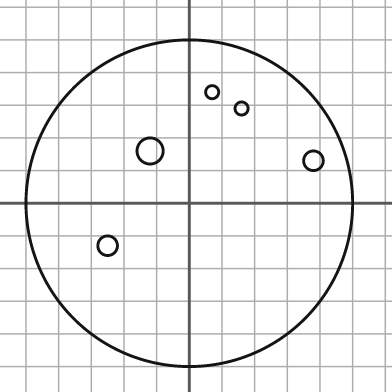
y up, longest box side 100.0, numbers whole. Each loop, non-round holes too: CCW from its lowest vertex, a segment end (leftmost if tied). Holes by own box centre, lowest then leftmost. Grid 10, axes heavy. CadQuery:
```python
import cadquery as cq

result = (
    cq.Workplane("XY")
    .moveTo(0.0, 0.0)
    .circle(50.0)
    .moveTo(-25.0, -13.0)
    .circle(3.0)
    .moveTo(38.0, 13.0)
    .circle(3.0)
    .moveTo(-12.0, 16.0)
    .circle(4.0)
    .moveTo(16.0, 29.0)
    .circle(2.0)
    .moveTo(7.0, 34.0)
    .circle(2.0)
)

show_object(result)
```